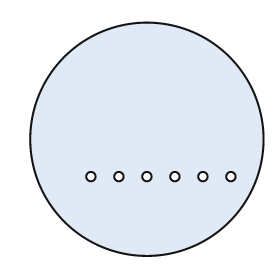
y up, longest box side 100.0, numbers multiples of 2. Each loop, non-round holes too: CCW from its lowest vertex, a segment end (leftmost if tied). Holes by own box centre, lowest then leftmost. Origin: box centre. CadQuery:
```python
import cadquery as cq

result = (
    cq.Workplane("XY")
    .moveTo(0.0, 0.0)
    .circle(50.0)
    .moveTo(-24.0, -16.0)
    .circle(2.0)
    .moveTo(-12.0, -16.0)
    .circle(2.0)
    .moveTo(0.0, -16.0)
    .circle(2.0)
    .moveTo(12.0, -16.0)
    .circle(2.0)
    .moveTo(24.0, -16.0)
    .circle(2.0)
    .moveTo(36.0, -16.0)
    .circle(2.0)
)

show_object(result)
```